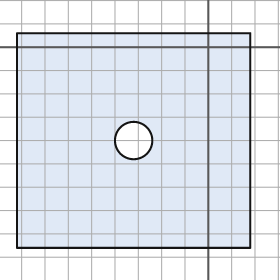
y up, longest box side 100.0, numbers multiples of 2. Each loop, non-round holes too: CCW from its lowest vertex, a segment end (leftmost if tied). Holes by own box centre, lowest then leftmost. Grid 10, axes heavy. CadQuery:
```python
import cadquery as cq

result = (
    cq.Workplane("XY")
    .moveTo(-82.0, -86.0)
    .lineTo(18.0, -86.0)
    .lineTo(18.0, 6.0)
    .lineTo(-82.0, 6.0)
    .close()
    .moveTo(-32.0, -40.0)
    .circle(8.0)
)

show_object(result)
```